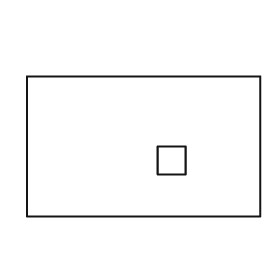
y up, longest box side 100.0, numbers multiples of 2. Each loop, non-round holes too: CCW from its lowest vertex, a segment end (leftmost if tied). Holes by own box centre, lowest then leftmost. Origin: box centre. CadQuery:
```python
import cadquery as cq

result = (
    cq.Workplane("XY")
    .moveTo(-50.0, -30.0)
    .lineTo(50.0, -30.0)
    .lineTo(50.0, 30.0)
    .lineTo(-50.0, 30.0)
    .close()
    .moveTo(6.0, -12.0)
    .lineTo(18.0, -12.0)
    .lineTo(18.0, 0.0)
    .lineTo(6.0, 0.0)
    .close()
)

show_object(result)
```